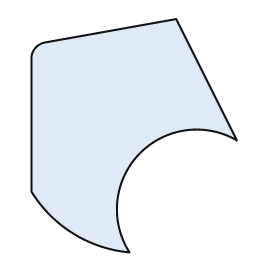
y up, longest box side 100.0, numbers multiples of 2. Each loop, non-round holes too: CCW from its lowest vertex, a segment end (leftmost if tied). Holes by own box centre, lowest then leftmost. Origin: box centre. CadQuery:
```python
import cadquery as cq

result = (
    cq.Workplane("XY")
    .moveTo(-2.0, -50.0)
    .threePointArc((2.0, -8.0), (44.0, -2.0))
    .lineTo(18.0, 50.0)
    .lineTo(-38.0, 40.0)
    .threePointArc((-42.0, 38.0), (-44.0, 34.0))
    .lineTo(-44.0, -24.0)
    .threePointArc((-26.0, -42.0), (-2.0, -50.0))
    .close()
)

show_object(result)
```